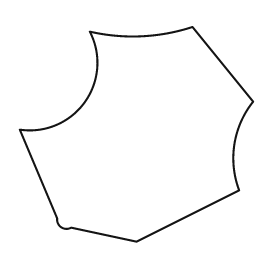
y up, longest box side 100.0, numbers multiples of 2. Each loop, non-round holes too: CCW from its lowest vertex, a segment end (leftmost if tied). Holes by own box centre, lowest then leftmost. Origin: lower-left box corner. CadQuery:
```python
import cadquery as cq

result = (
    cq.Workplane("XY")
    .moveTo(50.0, 0.0)
    .lineTo(94.0, 22.0)
    .threePointArc((92.0, 42.0), (100.0, 60.0))
    .lineTo(74.0, 92.0)
    .threePointArc((52.0, 88.0), (30.0, 90.0))
    .threePointArc((28.0, 60.0), (0.0, 48.0))
    .lineTo(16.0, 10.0)
    .threePointArc((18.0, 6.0), (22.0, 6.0))
    .close()
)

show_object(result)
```